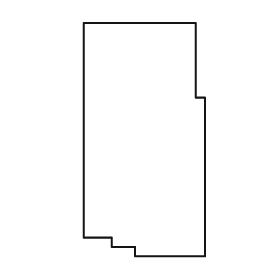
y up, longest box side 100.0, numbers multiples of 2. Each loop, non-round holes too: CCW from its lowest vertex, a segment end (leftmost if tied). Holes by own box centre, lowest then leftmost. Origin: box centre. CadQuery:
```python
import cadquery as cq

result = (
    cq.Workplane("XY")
    .moveTo(-4.0, -50.0)
    .lineTo(26.0, -50.0)
    .lineTo(26.0, 18.0)
    .lineTo(22.0, 18.0)
    .lineTo(22.0, 50.0)
    .lineTo(-26.0, 50.0)
    .lineTo(-26.0, -42.0)
    .lineTo(-14.0, -42.0)
    .lineTo(-14.0, -46.0)
    .lineTo(-4.0, -46.0)
    .close()
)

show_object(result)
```